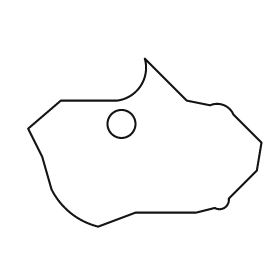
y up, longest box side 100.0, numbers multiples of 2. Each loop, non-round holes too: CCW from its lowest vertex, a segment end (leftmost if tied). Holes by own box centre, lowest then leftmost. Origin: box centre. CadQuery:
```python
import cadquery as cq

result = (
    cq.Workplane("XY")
    .moveTo(-20.0, -36.0)
    .lineTo(-4.0, -30.0)
    .lineTo(22.0, -30.0)
    .lineTo(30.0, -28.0)
    .threePointArc((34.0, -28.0), (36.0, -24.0))
    .lineTo(48.0, -12.0)
    .lineTo(50.0, 0.0)
    .lineTo(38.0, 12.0)
    .threePointArc((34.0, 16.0), (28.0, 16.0))
    .lineTo(18.0, 18.0)
    .lineTo(0.0, 36.0)
    .threePointArc((-2.0, 24.0), (-12.0, 18.0))
    .lineTo(-36.0, 18.0)
    .lineTo(-50.0, 6.0)
    .lineTo(-44.0, -6.0)
    .lineTo(-40.0, -20.0)
    .threePointArc((-32.0, -30.0), (-20.0, -36.0))
    .close()
    .moveTo(-10.0, 8.0)
    .circle(6.0)
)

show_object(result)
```